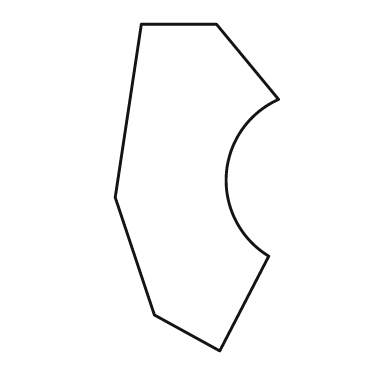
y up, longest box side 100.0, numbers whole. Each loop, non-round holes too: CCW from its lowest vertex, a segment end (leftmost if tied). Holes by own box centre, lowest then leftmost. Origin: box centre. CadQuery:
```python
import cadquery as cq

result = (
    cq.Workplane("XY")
    .moveTo(7.0, -50.0)
    .lineTo(22.0, -21.0)
    .threePointArc((9.0, 4.0), (25.0, 27.0))
    .lineTo(6.0, 50.0)
    .lineTo(-17.0, 50.0)
    .lineTo(-25.0, -3.0)
    .lineTo(-13.0, -39.0)
    .close()
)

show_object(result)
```